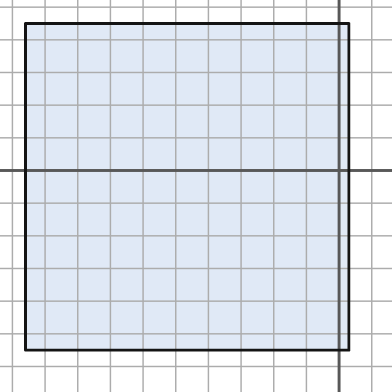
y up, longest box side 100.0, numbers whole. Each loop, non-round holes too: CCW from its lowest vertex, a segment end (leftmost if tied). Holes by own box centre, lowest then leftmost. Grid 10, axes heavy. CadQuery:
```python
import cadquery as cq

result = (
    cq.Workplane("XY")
    .moveTo(-96.0, -55.0)
    .lineTo(3.0, -55.0)
    .lineTo(3.0, 45.0)
    .lineTo(-96.0, 45.0)
    .close()
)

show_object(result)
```